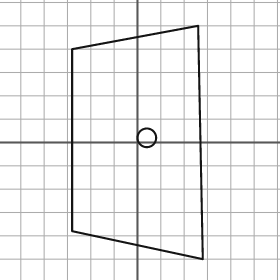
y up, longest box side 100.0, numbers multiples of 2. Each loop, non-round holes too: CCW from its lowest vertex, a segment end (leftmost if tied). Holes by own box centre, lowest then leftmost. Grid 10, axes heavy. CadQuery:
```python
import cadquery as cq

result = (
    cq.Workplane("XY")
    .moveTo(28.0, -50.0)
    .lineTo(26.0, 50.0)
    .lineTo(-28.0, 40.0)
    .lineTo(-28.0, -38.0)
    .close()
    .moveTo(4.0, 2.0)
    .circle(4.0)
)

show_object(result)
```